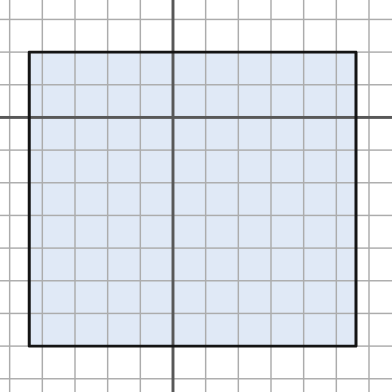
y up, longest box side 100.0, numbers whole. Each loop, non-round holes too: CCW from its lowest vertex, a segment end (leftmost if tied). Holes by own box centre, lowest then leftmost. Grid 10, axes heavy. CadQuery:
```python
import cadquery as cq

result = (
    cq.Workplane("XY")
    .moveTo(-44.0, -70.0)
    .lineTo(56.0, -70.0)
    .lineTo(56.0, 20.0)
    .lineTo(-44.0, 20.0)
    .close()
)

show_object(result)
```